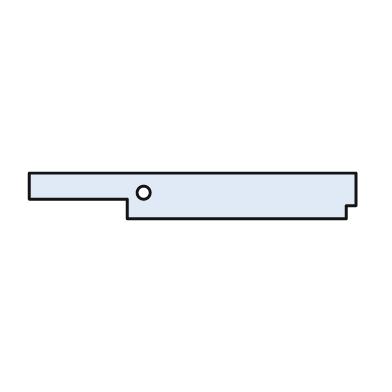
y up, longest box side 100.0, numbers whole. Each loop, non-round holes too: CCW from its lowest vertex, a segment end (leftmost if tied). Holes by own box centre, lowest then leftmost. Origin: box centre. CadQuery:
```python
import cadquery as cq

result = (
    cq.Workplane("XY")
    .moveTo(-20.0, -7.0)
    .lineTo(47.0, -7.0)
    .lineTo(47.0, -3.0)
    .lineTo(50.0, -3.0)
    .lineTo(50.0, 7.0)
    .lineTo(-50.0, 7.0)
    .lineTo(-50.0, -1.0)
    .lineTo(-20.0, -1.0)
    .close()
    .moveTo(-15.0, 1.0)
    .circle(2.0)
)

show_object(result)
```